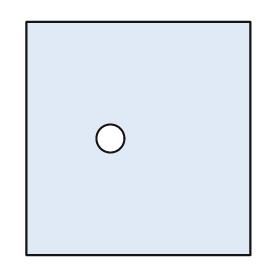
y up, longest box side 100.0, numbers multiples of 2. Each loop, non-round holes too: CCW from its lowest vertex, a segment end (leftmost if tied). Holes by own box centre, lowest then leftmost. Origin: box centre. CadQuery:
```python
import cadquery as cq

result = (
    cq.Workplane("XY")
    .moveTo(-48.0, -50.0)
    .lineTo(48.0, -50.0)
    .lineTo(48.0, 50.0)
    .lineTo(-48.0, 50.0)
    .close()
    .moveTo(-12.0, 0.0)
    .circle(6.0)
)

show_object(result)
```